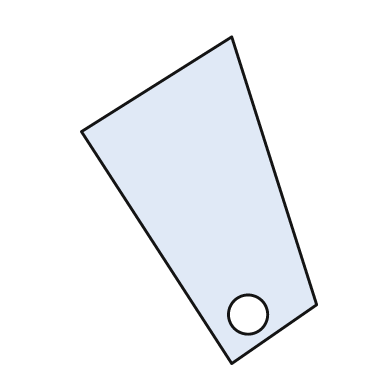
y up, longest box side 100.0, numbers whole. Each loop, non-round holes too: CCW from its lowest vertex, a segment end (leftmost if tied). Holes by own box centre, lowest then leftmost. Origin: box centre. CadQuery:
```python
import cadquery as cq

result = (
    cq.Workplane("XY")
    .moveTo(10.0, -50.0)
    .lineTo(36.0, -32.0)
    .lineTo(10.0, 50.0)
    .lineTo(-36.0, 21.0)
    .close()
    .moveTo(15.0, -35.0)
    .circle(6.0)
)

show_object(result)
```